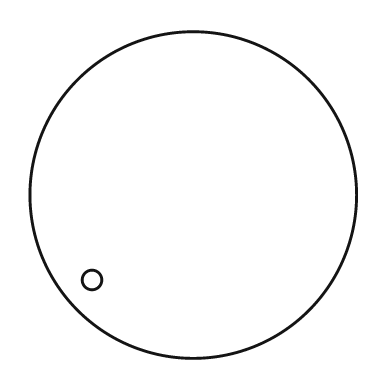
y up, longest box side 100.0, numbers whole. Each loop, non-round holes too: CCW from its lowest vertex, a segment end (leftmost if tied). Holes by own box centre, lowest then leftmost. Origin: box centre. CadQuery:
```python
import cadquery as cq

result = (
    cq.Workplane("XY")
    .moveTo(0.0, 0.0)
    .circle(50.0)
    .moveTo(-31.0, -26.0)
    .circle(3.0)
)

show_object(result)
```